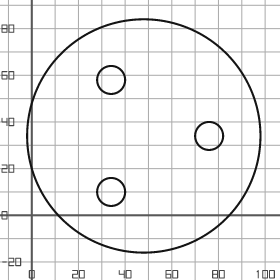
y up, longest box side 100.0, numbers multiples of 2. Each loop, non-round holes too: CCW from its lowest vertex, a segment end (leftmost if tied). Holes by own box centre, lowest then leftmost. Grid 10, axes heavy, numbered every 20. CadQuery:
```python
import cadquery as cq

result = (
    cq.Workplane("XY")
    .moveTo(48.0, 34.0)
    .circle(50.0)
    .moveTo(34.0, 10.0)
    .circle(6.0)
    .moveTo(76.0, 34.0)
    .circle(6.0)
    .moveTo(34.0, 58.0)
    .circle(6.0)
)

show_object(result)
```